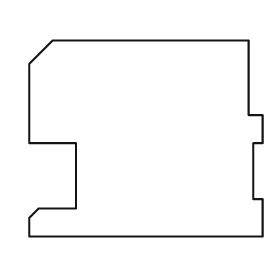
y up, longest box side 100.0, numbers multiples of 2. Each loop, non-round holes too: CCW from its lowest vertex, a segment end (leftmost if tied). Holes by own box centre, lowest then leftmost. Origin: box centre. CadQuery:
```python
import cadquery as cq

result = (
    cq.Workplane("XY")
    .moveTo(-50.0, -42.0)
    .lineTo(50.0, -42.0)
    .lineTo(50.0, -26.0)
    .lineTo(46.0, -26.0)
    .lineTo(46.0, -2.0)
    .lineTo(50.0, -2.0)
    .lineTo(50.0, 10.0)
    .lineTo(44.0, 10.0)
    .lineTo(44.0, 42.0)
    .lineTo(-40.0, 42.0)
    .lineTo(-50.0, 32.0)
    .lineTo(-50.0, -2.0)
    .lineTo(-30.0, -2.0)
    .lineTo(-30.0, -30.0)
    .lineTo(-46.0, -30.0)
    .lineTo(-50.0, -34.0)
    .close()
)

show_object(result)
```